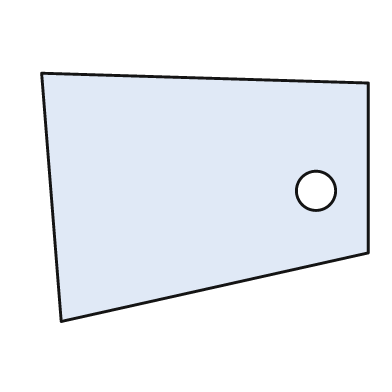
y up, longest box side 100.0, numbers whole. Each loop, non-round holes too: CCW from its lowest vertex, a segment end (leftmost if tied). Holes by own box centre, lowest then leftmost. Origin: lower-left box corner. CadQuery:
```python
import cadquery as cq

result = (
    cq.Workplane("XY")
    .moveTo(6.0, 0.0)
    .lineTo(100.0, 21.0)
    .lineTo(100.0, 73.0)
    .lineTo(0.0, 76.0)
    .close()
    .moveTo(84.0, 40.0)
    .circle(6.0)
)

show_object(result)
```